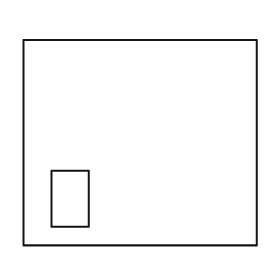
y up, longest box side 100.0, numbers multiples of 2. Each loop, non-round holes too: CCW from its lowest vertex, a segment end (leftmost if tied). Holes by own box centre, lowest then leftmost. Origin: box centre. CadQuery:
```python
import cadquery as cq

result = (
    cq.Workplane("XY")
    .moveTo(-50.0, -44.0)
    .lineTo(50.0, -44.0)
    .lineTo(50.0, 44.0)
    .lineTo(-50.0, 44.0)
    .close()
    .moveTo(-38.0, -36.0)
    .lineTo(-22.0, -36.0)
    .lineTo(-22.0, -12.0)
    .lineTo(-38.0, -12.0)
    .close()
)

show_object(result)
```